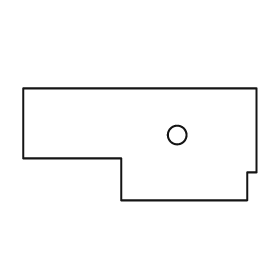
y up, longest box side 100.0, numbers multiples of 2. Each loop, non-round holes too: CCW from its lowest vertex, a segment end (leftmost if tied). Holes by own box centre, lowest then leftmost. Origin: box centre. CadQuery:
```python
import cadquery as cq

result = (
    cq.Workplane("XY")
    .moveTo(-8.0, -24.0)
    .lineTo(46.0, -24.0)
    .lineTo(46.0, -12.0)
    .lineTo(50.0, -12.0)
    .lineTo(50.0, 24.0)
    .lineTo(-50.0, 24.0)
    .lineTo(-50.0, -6.0)
    .lineTo(-8.0, -6.0)
    .close()
    .moveTo(16.0, 4.0)
    .circle(4.0)
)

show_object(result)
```